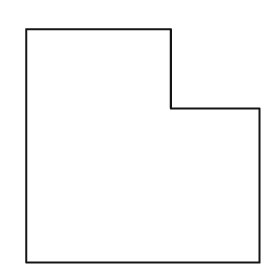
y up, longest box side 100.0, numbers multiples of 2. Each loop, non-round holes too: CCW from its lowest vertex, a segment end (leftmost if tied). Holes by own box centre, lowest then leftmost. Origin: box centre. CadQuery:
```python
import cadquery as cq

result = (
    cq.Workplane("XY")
    .moveTo(-50.0, -50.0)
    .lineTo(50.0, -50.0)
    .lineTo(50.0, 16.0)
    .lineTo(12.0, 16.0)
    .lineTo(12.0, 50.0)
    .lineTo(-50.0, 50.0)
    .close()
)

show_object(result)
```